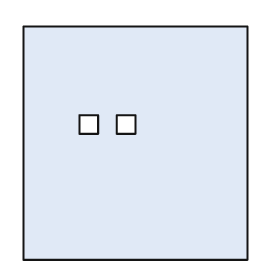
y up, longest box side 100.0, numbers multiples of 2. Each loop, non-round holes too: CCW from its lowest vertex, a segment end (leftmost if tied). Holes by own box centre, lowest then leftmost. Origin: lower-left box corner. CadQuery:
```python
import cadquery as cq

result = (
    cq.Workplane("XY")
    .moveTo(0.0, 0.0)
    .lineTo(96.0, 0.0)
    .lineTo(96.0, 100.0)
    .lineTo(0.0, 100.0)
    .close()
    .moveTo(24.0, 54.0)
    .lineTo(32.0, 54.0)
    .lineTo(32.0, 62.0)
    .lineTo(24.0, 62.0)
    .close()
    .moveTo(40.0, 54.0)
    .lineTo(48.0, 54.0)
    .lineTo(48.0, 62.0)
    .lineTo(40.0, 62.0)
    .close()
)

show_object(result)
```